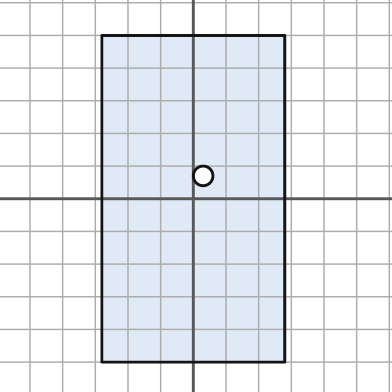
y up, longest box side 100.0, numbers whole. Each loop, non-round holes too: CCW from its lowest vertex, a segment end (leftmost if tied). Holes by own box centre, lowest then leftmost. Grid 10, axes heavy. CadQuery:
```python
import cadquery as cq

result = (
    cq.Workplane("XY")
    .moveTo(-28.0, -50.0)
    .lineTo(28.0, -50.0)
    .lineTo(28.0, 50.0)
    .lineTo(-28.0, 50.0)
    .close()
    .moveTo(3.0, 7.0)
    .circle(3.0)
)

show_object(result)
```